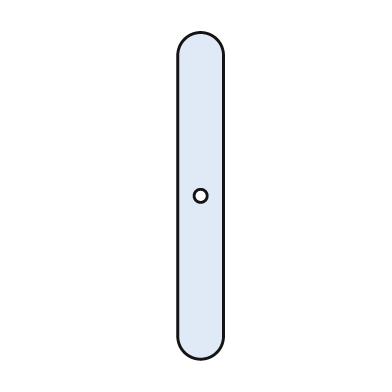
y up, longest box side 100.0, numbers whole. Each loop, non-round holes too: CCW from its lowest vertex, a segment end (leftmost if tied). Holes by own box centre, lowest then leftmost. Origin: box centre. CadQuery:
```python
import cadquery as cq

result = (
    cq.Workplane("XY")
    .moveTo(-7.0, -43.0)
    .threePointArc((0.0, -50.0), (7.0, -43.0))
    .lineTo(7.0, 43.0)
    .threePointArc((0.0, 50.0), (-7.0, 43.0))
    .close()
    .moveTo(0.0, 0.0)
    .circle(2.0)
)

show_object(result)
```